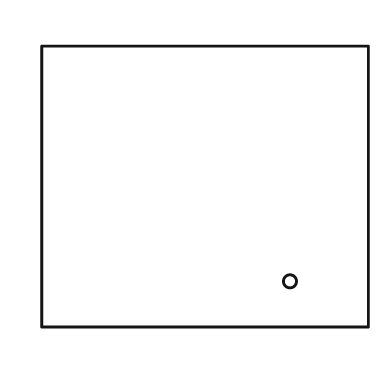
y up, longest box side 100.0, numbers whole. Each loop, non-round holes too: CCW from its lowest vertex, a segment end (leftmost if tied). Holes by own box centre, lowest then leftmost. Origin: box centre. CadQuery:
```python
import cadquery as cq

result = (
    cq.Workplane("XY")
    .moveTo(-50.0, -43.0)
    .lineTo(50.0, -43.0)
    .lineTo(50.0, 43.0)
    .lineTo(-50.0, 43.0)
    .close()
    .moveTo(26.0, -29.0)
    .circle(2.0)
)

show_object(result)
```